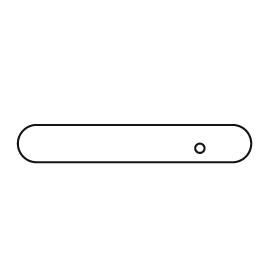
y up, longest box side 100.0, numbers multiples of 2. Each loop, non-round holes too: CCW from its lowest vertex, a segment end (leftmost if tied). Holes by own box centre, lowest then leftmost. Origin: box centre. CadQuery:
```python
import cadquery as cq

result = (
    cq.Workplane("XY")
    .moveTo(-42.0, -8.0)
    .lineTo(42.0, -8.0)
    .threePointArc((50.0, 0.0), (42.0, 8.0))
    .lineTo(-42.0, 8.0)
    .threePointArc((-50.0, 0.0), (-42.0, -8.0))
    .close()
    .moveTo(28.0, -2.0)
    .circle(2.0)
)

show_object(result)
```